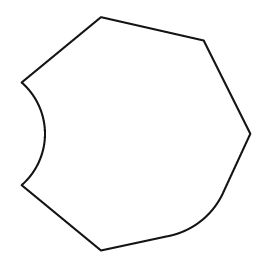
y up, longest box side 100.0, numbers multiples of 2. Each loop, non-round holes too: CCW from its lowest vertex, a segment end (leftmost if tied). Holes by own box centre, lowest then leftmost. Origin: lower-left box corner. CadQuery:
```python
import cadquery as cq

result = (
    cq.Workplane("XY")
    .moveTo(34.0, 0.0)
    .lineTo(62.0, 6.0)
    .threePointArc((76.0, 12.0), (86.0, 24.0))
    .lineTo(98.0, 50.0)
    .lineTo(78.0, 90.0)
    .lineTo(34.0, 100.0)
    .lineTo(0.0, 72.0)
    .threePointArc((10.0, 50.0), (0.0, 28.0))
    .close()
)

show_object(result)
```